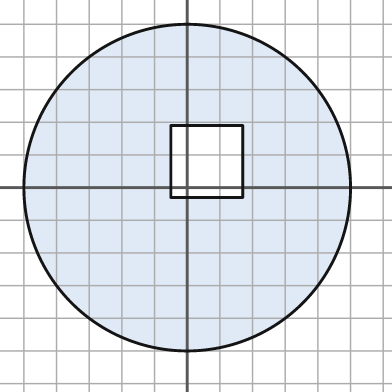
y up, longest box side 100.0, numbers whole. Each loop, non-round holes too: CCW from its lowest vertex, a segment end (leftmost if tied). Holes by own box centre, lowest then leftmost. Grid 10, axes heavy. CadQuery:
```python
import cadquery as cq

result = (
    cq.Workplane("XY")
    .moveTo(0.0, 0.0)
    .circle(50.0)
    .moveTo(-5.0, -3.0)
    .lineTo(17.0, -3.0)
    .lineTo(17.0, 19.0)
    .lineTo(-5.0, 19.0)
    .close()
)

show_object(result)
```